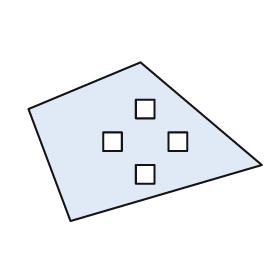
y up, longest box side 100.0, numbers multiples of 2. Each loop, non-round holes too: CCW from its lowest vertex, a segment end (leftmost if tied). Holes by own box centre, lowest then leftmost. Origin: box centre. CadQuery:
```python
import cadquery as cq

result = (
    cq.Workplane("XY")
    .moveTo(-32.0, -34.0)
    .lineTo(50.0, -10.0)
    .lineTo(-2.0, 34.0)
    .lineTo(-50.0, 14.0)
    .close()
    .moveTo(-4.0, -18.0)
    .lineTo(4.0, -18.0)
    .lineTo(4.0, -10.0)
    .lineTo(-4.0, -10.0)
    .close()
    .moveTo(-18.0, -4.0)
    .lineTo(-10.0, -4.0)
    .lineTo(-10.0, 4.0)
    .lineTo(-18.0, 4.0)
    .close()
    .moveTo(10.0, -4.0)
    .lineTo(18.0, -4.0)
    .lineTo(18.0, 4.0)
    .lineTo(10.0, 4.0)
    .close()
    .moveTo(-4.0, 10.0)
    .lineTo(4.0, 10.0)
    .lineTo(4.0, 18.0)
    .lineTo(-4.0, 18.0)
    .close()
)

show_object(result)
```